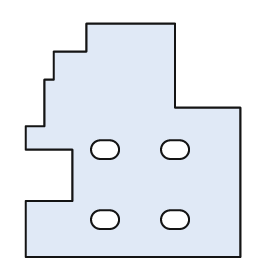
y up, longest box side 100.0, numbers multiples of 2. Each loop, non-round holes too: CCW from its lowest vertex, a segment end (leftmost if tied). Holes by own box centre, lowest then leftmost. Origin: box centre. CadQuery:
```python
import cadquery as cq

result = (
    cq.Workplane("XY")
    .moveTo(-46.0, -50.0)
    .lineTo(46.0, -50.0)
    .lineTo(46.0, 14.0)
    .lineTo(18.0, 14.0)
    .lineTo(18.0, 50.0)
    .lineTo(-20.0, 50.0)
    .lineTo(-20.0, 38.0)
    .lineTo(-34.0, 38.0)
    .lineTo(-34.0, 26.0)
    .lineTo(-38.0, 26.0)
    .lineTo(-38.0, 6.0)
    .lineTo(-46.0, 6.0)
    .lineTo(-46.0, -4.0)
    .lineTo(-26.0, -4.0)
    .lineTo(-26.0, -26.0)
    .lineTo(-46.0, -26.0)
    .close()
    .moveTo(-14.0, -38.0)
    .lineTo(-10.0, -38.0)
    .threePointArc((-6.0, -34.0), (-10.0, -30.0))
    .lineTo(-14.0, -30.0)
    .threePointArc((-18.0, -34.0), (-14.0, -38.0))
    .close()
    .moveTo(16.0, -38.0)
    .lineTo(20.0, -38.0)
    .threePointArc((24.0, -34.0), (20.0, -30.0))
    .lineTo(16.0, -30.0)
    .threePointArc((12.0, -34.0), (16.0, -38.0))
    .close()
    .moveTo(-14.0, -8.0)
    .lineTo(-10.0, -8.0)
    .threePointArc((-6.0, -4.0), (-10.0, 0.0))
    .lineTo(-14.0, 0.0)
    .threePointArc((-18.0, -4.0), (-14.0, -8.0))
    .close()
    .moveTo(16.0, -8.0)
    .lineTo(20.0, -8.0)
    .threePointArc((24.0, -4.0), (20.0, 0.0))
    .lineTo(16.0, 0.0)
    .threePointArc((12.0, -4.0), (16.0, -8.0))
    .close()
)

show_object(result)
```